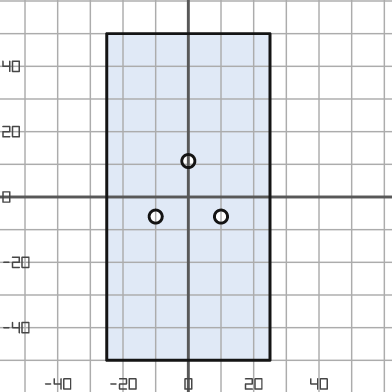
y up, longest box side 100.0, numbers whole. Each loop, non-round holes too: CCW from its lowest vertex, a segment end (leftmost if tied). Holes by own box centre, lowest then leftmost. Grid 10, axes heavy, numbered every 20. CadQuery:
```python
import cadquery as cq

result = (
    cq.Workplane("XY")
    .moveTo(-25.0, -50.0)
    .lineTo(25.0, -50.0)
    .lineTo(25.0, 50.0)
    .lineTo(-25.0, 50.0)
    .close()
    .moveTo(-10.0, -6.0)
    .circle(2.0)
    .moveTo(10.0, -6.0)
    .circle(2.0)
    .moveTo(0.0, 11.0)
    .circle(2.0)
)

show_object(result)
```